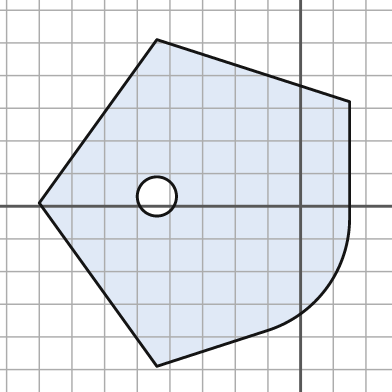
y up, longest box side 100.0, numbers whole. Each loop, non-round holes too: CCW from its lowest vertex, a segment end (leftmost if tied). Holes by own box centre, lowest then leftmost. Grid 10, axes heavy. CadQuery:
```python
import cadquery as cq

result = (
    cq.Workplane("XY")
    .moveTo(-44.0, -49.0)
    .lineTo(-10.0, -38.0)
    .threePointArc((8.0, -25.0), (15.0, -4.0))
    .lineTo(15.0, 32.0)
    .lineTo(-44.0, 51.0)
    .lineTo(-80.0, 1.0)
    .close()
    .moveTo(-44.0, 3.0)
    .circle(6.0)
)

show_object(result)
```